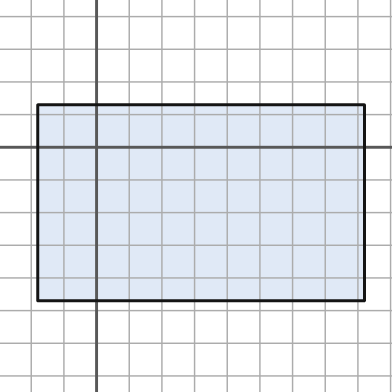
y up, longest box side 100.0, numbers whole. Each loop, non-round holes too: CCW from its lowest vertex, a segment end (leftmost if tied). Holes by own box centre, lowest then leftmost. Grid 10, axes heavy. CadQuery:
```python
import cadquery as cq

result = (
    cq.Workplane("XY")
    .moveTo(-18.0, -47.0)
    .lineTo(82.0, -47.0)
    .lineTo(82.0, 13.0)
    .lineTo(-18.0, 13.0)
    .close()
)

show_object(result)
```